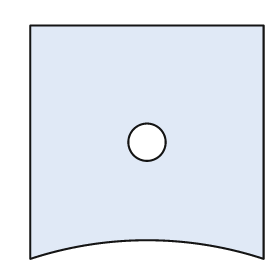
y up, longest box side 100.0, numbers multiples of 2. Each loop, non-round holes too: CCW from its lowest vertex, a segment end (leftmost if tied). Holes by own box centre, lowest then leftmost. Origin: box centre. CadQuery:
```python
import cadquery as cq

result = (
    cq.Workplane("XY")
    .moveTo(-50.0, -50.0)
    .threePointArc((0.0, -42.0), (50.0, -50.0))
    .lineTo(50.0, 50.0)
    .lineTo(-50.0, 50.0)
    .close()
    .moveTo(0.0, 0.0)
    .circle(8.0)
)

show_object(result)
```